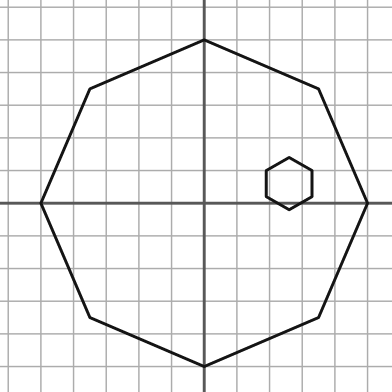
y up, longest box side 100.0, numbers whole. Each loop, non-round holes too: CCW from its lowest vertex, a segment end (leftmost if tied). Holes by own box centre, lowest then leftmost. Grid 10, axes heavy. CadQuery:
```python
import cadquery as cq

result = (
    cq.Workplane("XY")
    .moveTo(0.0, -50.0)
    .lineTo(35.0, -35.0)
    .lineTo(50.0, 0.0)
    .lineTo(35.0, 35.0)
    .lineTo(0.0, 50.0)
    .lineTo(-35.0, 35.0)
    .lineTo(-50.0, 0.0)
    .lineTo(-35.0, -35.0)
    .close()
    .moveTo(26.0, -2.0)
    .lineTo(33.0, 2.0)
    .lineTo(33.0, 10.0)
    .lineTo(26.0, 14.0)
    .lineTo(19.0, 10.0)
    .lineTo(19.0, 2.0)
    .close()
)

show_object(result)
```